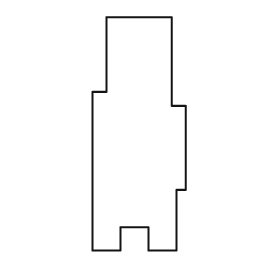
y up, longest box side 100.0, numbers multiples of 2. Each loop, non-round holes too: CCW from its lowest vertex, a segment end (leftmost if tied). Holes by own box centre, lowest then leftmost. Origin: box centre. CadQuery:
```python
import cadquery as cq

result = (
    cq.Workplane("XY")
    .moveTo(-20.0, -50.0)
    .lineTo(-8.0, -50.0)
    .lineTo(-8.0, -40.0)
    .lineTo(4.0, -40.0)
    .lineTo(4.0, -50.0)
    .lineTo(16.0, -50.0)
    .lineTo(16.0, -24.0)
    .lineTo(20.0, -24.0)
    .lineTo(20.0, 12.0)
    .lineTo(14.0, 12.0)
    .lineTo(14.0, 50.0)
    .lineTo(-14.0, 50.0)
    .lineTo(-14.0, 18.0)
    .lineTo(-20.0, 18.0)
    .close()
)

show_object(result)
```